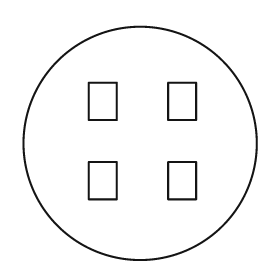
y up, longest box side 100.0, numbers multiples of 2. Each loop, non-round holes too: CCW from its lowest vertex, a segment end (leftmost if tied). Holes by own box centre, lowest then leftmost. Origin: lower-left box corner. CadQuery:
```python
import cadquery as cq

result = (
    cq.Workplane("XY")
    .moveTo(50.0, 50.0)
    .circle(50.0)
    .moveTo(28.0, 26.0)
    .lineTo(40.0, 26.0)
    .lineTo(40.0, 42.0)
    .lineTo(28.0, 42.0)
    .close()
    .moveTo(62.0, 26.0)
    .lineTo(74.0, 26.0)
    .lineTo(74.0, 42.0)
    .lineTo(62.0, 42.0)
    .close()
    .moveTo(28.0, 60.0)
    .lineTo(40.0, 60.0)
    .lineTo(40.0, 76.0)
    .lineTo(28.0, 76.0)
    .close()
    .moveTo(62.0, 60.0)
    .lineTo(74.0, 60.0)
    .lineTo(74.0, 76.0)
    .lineTo(62.0, 76.0)
    .close()
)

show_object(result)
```